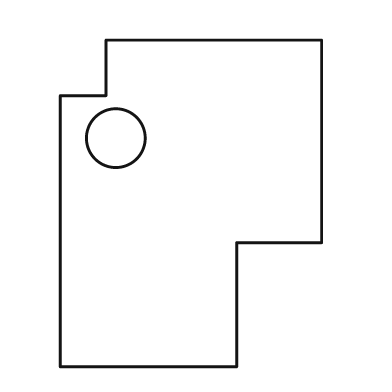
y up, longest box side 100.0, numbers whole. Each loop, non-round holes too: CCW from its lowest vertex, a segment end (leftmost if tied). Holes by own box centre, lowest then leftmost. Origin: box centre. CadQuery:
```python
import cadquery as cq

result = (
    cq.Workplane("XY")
    .moveTo(-40.0, -50.0)
    .lineTo(14.0, -50.0)
    .lineTo(14.0, -12.0)
    .lineTo(40.0, -12.0)
    .lineTo(40.0, 50.0)
    .lineTo(-26.0, 50.0)
    .lineTo(-26.0, 33.0)
    .lineTo(-40.0, 33.0)
    .close()
    .moveTo(-23.0, 20.0)
    .circle(9.0)
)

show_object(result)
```